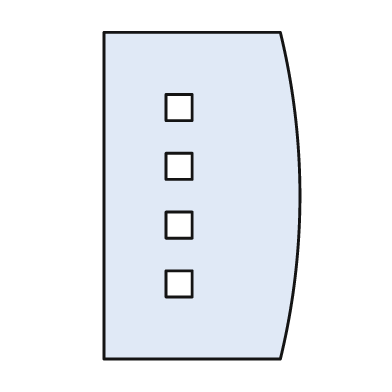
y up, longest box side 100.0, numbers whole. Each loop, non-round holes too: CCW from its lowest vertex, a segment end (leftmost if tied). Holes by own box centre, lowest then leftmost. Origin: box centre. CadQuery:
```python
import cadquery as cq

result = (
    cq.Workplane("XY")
    .moveTo(-30.0, -50.0)
    .lineTo(24.0, -50.0)
    .threePointArc((30.0, 0.0), (24.0, 50.0))
    .lineTo(-30.0, 50.0)
    .close()
    .moveTo(-11.0, -31.0)
    .lineTo(-3.0, -31.0)
    .lineTo(-3.0, -23.0)
    .lineTo(-11.0, -23.0)
    .close()
    .moveTo(-11.0, -13.0)
    .lineTo(-3.0, -13.0)
    .lineTo(-3.0, -5.0)
    .lineTo(-11.0, -5.0)
    .close()
    .moveTo(-11.0, 5.0)
    .lineTo(-3.0, 5.0)
    .lineTo(-3.0, 13.0)
    .lineTo(-11.0, 13.0)
    .close()
    .moveTo(-11.0, 23.0)
    .lineTo(-3.0, 23.0)
    .lineTo(-3.0, 31.0)
    .lineTo(-11.0, 31.0)
    .close()
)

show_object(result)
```